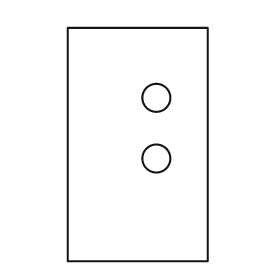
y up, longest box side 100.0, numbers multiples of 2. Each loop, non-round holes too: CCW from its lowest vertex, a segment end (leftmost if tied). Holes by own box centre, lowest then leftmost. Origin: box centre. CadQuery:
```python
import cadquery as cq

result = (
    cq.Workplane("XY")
    .moveTo(-30.0, -50.0)
    .lineTo(30.0, -50.0)
    .lineTo(30.0, 50.0)
    .lineTo(-30.0, 50.0)
    .close()
    .moveTo(8.0, -6.0)
    .circle(6.0)
    .moveTo(8.0, 20.0)
    .circle(6.0)
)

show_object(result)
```